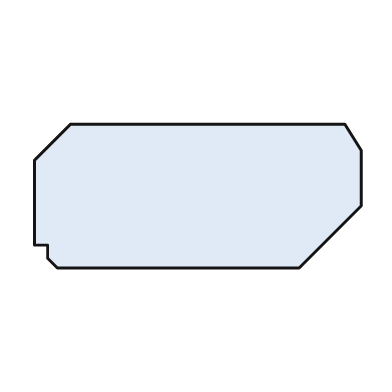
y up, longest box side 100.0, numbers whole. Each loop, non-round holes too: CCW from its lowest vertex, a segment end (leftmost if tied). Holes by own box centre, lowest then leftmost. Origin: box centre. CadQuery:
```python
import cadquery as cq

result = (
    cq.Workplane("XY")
    .moveTo(-43.0, -22.0)
    .lineTo(31.0, -22.0)
    .lineTo(50.0, -3.0)
    .lineTo(50.0, 14.0)
    .lineTo(45.0, 22.0)
    .lineTo(-39.0, 22.0)
    .lineTo(-50.0, 11.0)
    .lineTo(-50.0, -15.0)
    .lineTo(-46.0, -15.0)
    .lineTo(-46.0, -19.0)
    .close()
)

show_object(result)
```